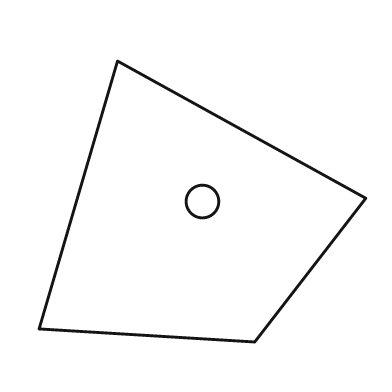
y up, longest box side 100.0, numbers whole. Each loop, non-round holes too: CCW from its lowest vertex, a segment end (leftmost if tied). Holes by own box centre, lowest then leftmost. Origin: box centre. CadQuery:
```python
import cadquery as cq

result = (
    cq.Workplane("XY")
    .moveTo(16.0, -43.0)
    .lineTo(50.0, 1.0)
    .lineTo(-26.0, 43.0)
    .lineTo(-50.0, -39.0)
    .close()
    .moveTo(0.0, 0.0)
    .circle(5.0)
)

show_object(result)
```